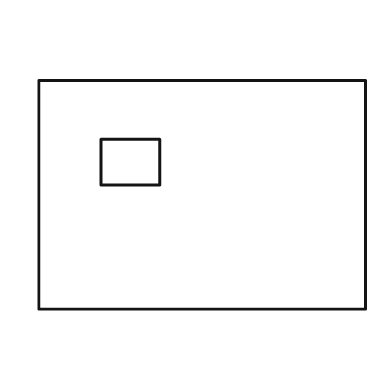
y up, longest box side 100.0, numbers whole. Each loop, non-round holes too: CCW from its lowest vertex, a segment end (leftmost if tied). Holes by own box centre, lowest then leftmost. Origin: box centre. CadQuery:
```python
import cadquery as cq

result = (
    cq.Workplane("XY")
    .moveTo(-50.0, -35.0)
    .lineTo(50.0, -35.0)
    .lineTo(50.0, 35.0)
    .lineTo(-50.0, 35.0)
    .close()
    .moveTo(-31.0, 3.0)
    .lineTo(-13.0, 3.0)
    .lineTo(-13.0, 17.0)
    .lineTo(-31.0, 17.0)
    .close()
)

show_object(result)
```